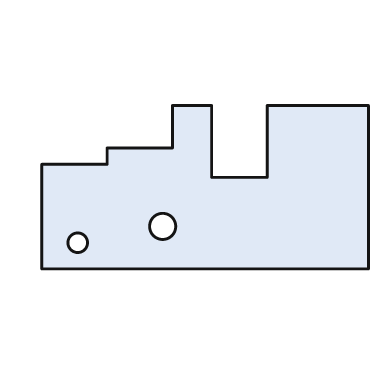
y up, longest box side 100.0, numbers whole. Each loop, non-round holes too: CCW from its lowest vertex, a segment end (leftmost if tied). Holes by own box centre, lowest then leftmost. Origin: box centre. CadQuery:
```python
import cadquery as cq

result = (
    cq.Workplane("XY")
    .moveTo(-50.0, -25.0)
    .lineTo(50.0, -25.0)
    .lineTo(50.0, 25.0)
    .lineTo(19.0, 25.0)
    .lineTo(19.0, 3.0)
    .lineTo(2.0, 3.0)
    .lineTo(2.0, 25.0)
    .lineTo(-10.0, 25.0)
    .lineTo(-10.0, 12.0)
    .lineTo(-30.0, 12.0)
    .lineTo(-30.0, 7.0)
    .lineTo(-50.0, 7.0)
    .close()
    .moveTo(-39.0, -17.0)
    .circle(3.0)
    .moveTo(-13.0, -12.0)
    .circle(4.0)
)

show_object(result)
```